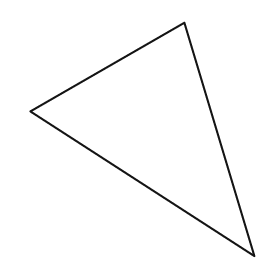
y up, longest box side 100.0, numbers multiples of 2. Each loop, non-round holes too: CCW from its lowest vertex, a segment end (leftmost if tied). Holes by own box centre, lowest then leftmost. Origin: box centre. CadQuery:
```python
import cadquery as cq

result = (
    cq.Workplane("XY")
    .moveTo(48.0, -50.0)
    .lineTo(18.0, 50.0)
    .lineTo(-48.0, 12.0)
    .close()
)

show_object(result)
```